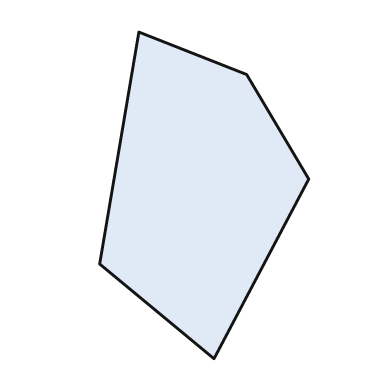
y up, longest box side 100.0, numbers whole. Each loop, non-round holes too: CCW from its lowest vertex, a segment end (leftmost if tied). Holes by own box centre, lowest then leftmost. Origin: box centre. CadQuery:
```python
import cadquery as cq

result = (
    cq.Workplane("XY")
    .moveTo(3.0, -50.0)
    .lineTo(32.0, 5.0)
    .lineTo(13.0, 37.0)
    .lineTo(-20.0, 50.0)
    .lineTo(-32.0, -21.0)
    .close()
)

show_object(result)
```